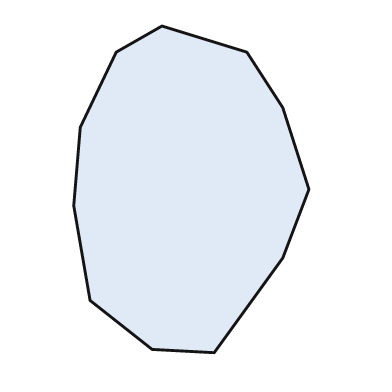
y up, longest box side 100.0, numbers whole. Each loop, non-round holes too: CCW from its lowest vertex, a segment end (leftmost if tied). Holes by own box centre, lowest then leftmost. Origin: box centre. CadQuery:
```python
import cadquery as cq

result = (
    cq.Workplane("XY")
    .moveTo(7.0, -50.0)
    .lineTo(28.0, -21.0)
    .lineTo(36.0, 0.0)
    .lineTo(28.0, 25.0)
    .lineTo(17.0, 42.0)
    .lineTo(-9.0, 50.0)
    .lineTo(-23.0, 42.0)
    .lineTo(-34.0, 19.0)
    .lineTo(-36.0, -5.0)
    .lineTo(-31.0, -34.0)
    .lineTo(-12.0, -49.0)
    .close()
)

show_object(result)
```